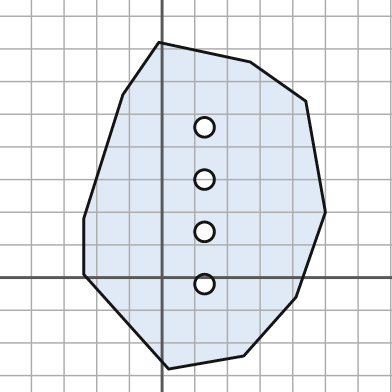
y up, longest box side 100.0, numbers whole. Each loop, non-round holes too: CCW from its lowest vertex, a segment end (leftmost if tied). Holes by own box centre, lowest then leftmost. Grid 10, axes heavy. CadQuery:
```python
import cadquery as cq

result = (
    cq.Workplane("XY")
    .moveTo(2.0, -28.0)
    .lineTo(25.0, -24.0)
    .lineTo(41.0, -6.0)
    .lineTo(50.0, 20.0)
    .lineTo(44.0, 54.0)
    .lineTo(27.0, 66.0)
    .lineTo(-1.0, 72.0)
    .lineTo(-12.0, 56.0)
    .lineTo(-24.0, 18.0)
    .lineTo(-24.0, 1.0)
    .close()
    .moveTo(13.0, -2.0)
    .circle(3.0)
    .moveTo(13.0, 14.0)
    .circle(3.0)
    .moveTo(13.0, 30.0)
    .circle(3.0)
    .moveTo(13.0, 46.0)
    .circle(3.0)
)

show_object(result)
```